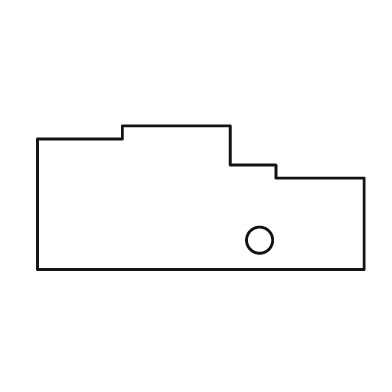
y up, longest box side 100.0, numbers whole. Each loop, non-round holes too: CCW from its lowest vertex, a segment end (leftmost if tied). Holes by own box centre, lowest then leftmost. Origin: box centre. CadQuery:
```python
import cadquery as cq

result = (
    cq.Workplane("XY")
    .moveTo(-50.0, -22.0)
    .lineTo(50.0, -22.0)
    .lineTo(50.0, 6.0)
    .lineTo(23.0, 6.0)
    .lineTo(23.0, 10.0)
    .lineTo(9.0, 10.0)
    .lineTo(9.0, 22.0)
    .lineTo(-24.0, 22.0)
    .lineTo(-24.0, 18.0)
    .lineTo(-50.0, 18.0)
    .close()
    .moveTo(18.0, -13.0)
    .circle(4.0)
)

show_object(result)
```